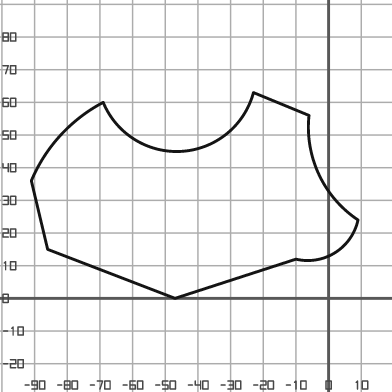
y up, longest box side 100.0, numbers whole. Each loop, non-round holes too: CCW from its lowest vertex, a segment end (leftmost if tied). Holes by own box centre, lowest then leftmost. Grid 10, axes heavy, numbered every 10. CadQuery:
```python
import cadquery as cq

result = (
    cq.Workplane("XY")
    .moveTo(-47.0, 0.0)
    .lineTo(-10.0, 12.0)
    .threePointArc((2.0, 14.0), (9.0, 24.0))
    .threePointArc((-3.0, 38.0), (-6.0, 56.0))
    .lineTo(-23.0, 63.0)
    .threePointArc((-45.0, 45.0), (-69.0, 60.0))
    .threePointArc((-82.0, 50.0), (-91.0, 36.0))
    .lineTo(-86.0, 15.0)
    .close()
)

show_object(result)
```